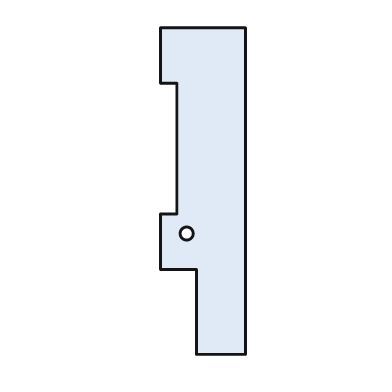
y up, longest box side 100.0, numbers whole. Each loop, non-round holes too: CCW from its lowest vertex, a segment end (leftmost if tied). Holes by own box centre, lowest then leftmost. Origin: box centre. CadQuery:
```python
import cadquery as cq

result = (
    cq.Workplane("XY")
    .moveTo(-2.0, -50.0)
    .lineTo(13.0, -50.0)
    .lineTo(13.0, 50.0)
    .lineTo(-13.0, 50.0)
    .lineTo(-13.0, 33.0)
    .lineTo(-8.0, 33.0)
    .lineTo(-8.0, -7.0)
    .lineTo(-13.0, -7.0)
    .lineTo(-13.0, -24.0)
    .lineTo(-2.0, -24.0)
    .close()
    .moveTo(-5.0, -13.0)
    .circle(2.0)
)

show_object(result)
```